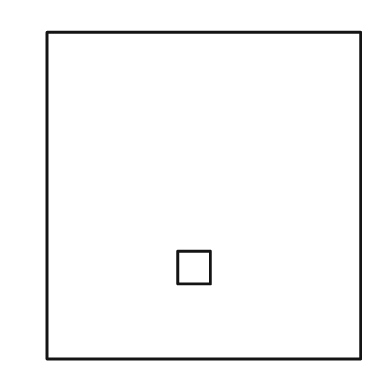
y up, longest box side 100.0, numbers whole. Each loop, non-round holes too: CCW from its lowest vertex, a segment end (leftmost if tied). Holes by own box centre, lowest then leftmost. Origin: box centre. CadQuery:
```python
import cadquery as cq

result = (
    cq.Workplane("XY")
    .moveTo(-48.0, -50.0)
    .lineTo(48.0, -50.0)
    .lineTo(48.0, 50.0)
    .lineTo(-48.0, 50.0)
    .close()
    .moveTo(-8.0, -27.0)
    .lineTo(2.0, -27.0)
    .lineTo(2.0, -17.0)
    .lineTo(-8.0, -17.0)
    .close()
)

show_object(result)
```